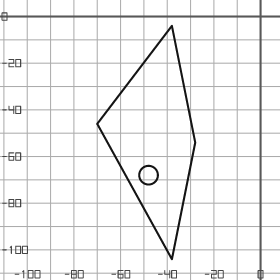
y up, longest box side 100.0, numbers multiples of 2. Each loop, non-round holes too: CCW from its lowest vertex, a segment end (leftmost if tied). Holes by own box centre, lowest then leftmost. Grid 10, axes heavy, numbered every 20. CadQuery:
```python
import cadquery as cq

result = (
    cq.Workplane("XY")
    .moveTo(-38.0, -104.0)
    .lineTo(-28.0, -54.0)
    .lineTo(-38.0, -4.0)
    .lineTo(-70.0, -46.0)
    .close()
    .moveTo(-48.0, -68.0)
    .circle(4.0)
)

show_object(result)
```